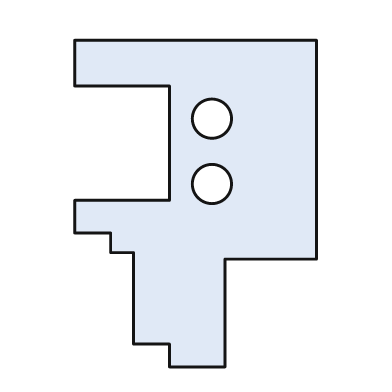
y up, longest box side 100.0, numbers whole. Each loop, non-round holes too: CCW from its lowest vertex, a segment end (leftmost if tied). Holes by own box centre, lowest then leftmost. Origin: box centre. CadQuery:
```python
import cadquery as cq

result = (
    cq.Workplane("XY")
    .moveTo(-8.0, -50.0)
    .lineTo(9.0, -50.0)
    .lineTo(9.0, -17.0)
    .lineTo(37.0, -17.0)
    .lineTo(37.0, 50.0)
    .lineTo(-37.0, 50.0)
    .lineTo(-37.0, 36.0)
    .lineTo(-8.0, 36.0)
    .lineTo(-8.0, 1.0)
    .lineTo(-37.0, 1.0)
    .lineTo(-37.0, -9.0)
    .lineTo(-26.0, -9.0)
    .lineTo(-26.0, -15.0)
    .lineTo(-19.0, -15.0)
    .lineTo(-19.0, -43.0)
    .lineTo(-8.0, -43.0)
    .close()
    .moveTo(5.0, 6.0)
    .circle(6.0)
    .moveTo(5.0, 26.0)
    .circle(6.0)
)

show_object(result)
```